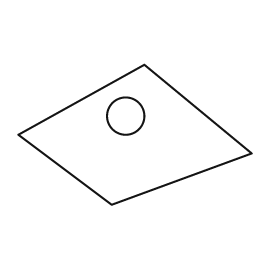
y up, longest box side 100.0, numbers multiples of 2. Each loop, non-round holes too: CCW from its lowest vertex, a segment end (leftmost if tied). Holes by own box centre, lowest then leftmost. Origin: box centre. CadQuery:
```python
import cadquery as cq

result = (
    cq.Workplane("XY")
    .moveTo(-10.0, -30.0)
    .lineTo(50.0, -8.0)
    .lineTo(4.0, 30.0)
    .lineTo(-50.0, 0.0)
    .close()
    .moveTo(-4.0, 8.0)
    .circle(8.0)
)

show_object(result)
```